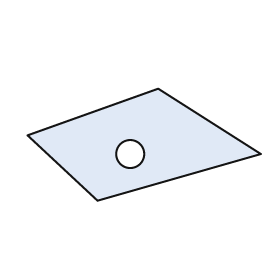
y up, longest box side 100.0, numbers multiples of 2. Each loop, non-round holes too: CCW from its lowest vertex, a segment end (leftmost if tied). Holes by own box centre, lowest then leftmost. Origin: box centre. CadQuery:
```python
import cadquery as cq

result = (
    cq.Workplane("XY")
    .moveTo(-20.0, -24.0)
    .lineTo(50.0, -4.0)
    .lineTo(6.0, 24.0)
    .lineTo(-50.0, 4.0)
    .close()
    .moveTo(-6.0, -4.0)
    .circle(6.0)
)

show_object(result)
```